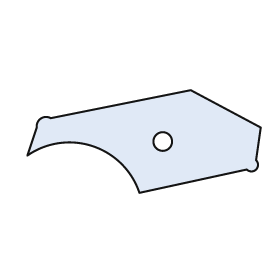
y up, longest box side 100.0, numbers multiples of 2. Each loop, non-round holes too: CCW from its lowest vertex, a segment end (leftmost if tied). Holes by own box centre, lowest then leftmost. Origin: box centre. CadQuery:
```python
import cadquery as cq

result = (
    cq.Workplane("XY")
    .moveTo(-2.0, -22.0)
    .lineTo(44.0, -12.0)
    .threePointArc((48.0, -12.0), (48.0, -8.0))
    .lineTo(50.0, 6.0)
    .lineTo(20.0, 22.0)
    .lineTo(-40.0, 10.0)
    .threePointArc((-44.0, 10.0), (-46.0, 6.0))
    .lineTo(-50.0, -6.0)
    .threePointArc((-22.0, -2.0), (-2.0, -22.0))
    .close()
    .moveTo(8.0, 0.0)
    .circle(4.0)
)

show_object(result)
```